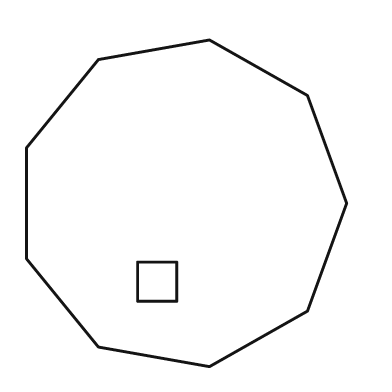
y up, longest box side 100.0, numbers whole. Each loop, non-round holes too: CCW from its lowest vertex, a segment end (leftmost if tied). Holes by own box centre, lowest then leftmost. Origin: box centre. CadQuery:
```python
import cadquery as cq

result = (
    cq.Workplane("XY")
    .moveTo(7.0, -50.0)
    .lineTo(37.0, -33.0)
    .lineTo(49.0, 0.0)
    .lineTo(37.0, 33.0)
    .lineTo(7.0, 50.0)
    .lineTo(-27.0, 44.0)
    .lineTo(-49.0, 17.0)
    .lineTo(-49.0, -17.0)
    .lineTo(-27.0, -44.0)
    .close()
    .moveTo(-15.0, -30.0)
    .lineTo(-3.0, -30.0)
    .lineTo(-3.0, -18.0)
    .lineTo(-15.0, -18.0)
    .close()
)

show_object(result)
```